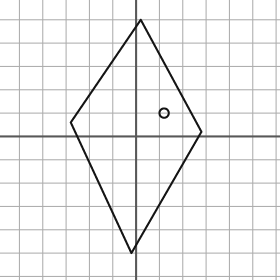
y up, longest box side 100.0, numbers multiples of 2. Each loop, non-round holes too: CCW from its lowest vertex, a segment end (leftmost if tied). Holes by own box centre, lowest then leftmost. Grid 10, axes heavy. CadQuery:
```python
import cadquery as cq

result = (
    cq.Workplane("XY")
    .moveTo(-2.0, -50.0)
    .lineTo(28.0, 2.0)
    .lineTo(2.0, 50.0)
    .lineTo(-28.0, 6.0)
    .close()
    .moveTo(12.0, 10.0)
    .circle(2.0)
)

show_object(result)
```